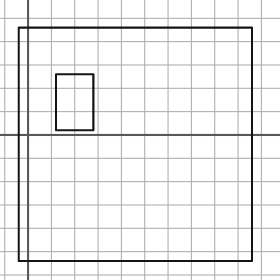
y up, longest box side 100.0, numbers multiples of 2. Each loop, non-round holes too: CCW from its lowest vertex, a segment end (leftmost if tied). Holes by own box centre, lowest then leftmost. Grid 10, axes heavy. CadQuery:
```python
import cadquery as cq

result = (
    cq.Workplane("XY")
    .moveTo(-4.0, -54.0)
    .lineTo(96.0, -54.0)
    .lineTo(96.0, 46.0)
    .lineTo(-4.0, 46.0)
    .close()
    .moveTo(12.0, 2.0)
    .lineTo(28.0, 2.0)
    .lineTo(28.0, 26.0)
    .lineTo(12.0, 26.0)
    .close()
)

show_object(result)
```